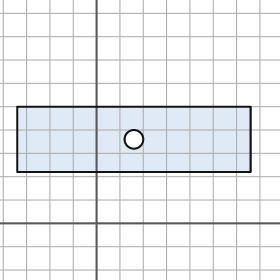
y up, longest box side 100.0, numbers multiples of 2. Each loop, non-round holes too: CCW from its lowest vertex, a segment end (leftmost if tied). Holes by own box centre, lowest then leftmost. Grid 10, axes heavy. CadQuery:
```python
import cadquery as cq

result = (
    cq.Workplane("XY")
    .moveTo(-34.0, 22.0)
    .lineTo(66.0, 22.0)
    .lineTo(66.0, 50.0)
    .lineTo(-34.0, 50.0)
    .close()
    .moveTo(16.0, 36.0)
    .circle(4.0)
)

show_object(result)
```